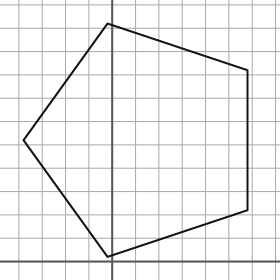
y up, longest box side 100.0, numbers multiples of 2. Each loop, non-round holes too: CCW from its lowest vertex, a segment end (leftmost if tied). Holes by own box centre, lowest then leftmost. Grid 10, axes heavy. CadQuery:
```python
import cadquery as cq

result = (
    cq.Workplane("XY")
    .moveTo(-2.0, 2.0)
    .lineTo(58.0, 22.0)
    .lineTo(58.0, 82.0)
    .lineTo(-2.0, 102.0)
    .lineTo(-38.0, 52.0)
    .close()
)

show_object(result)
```